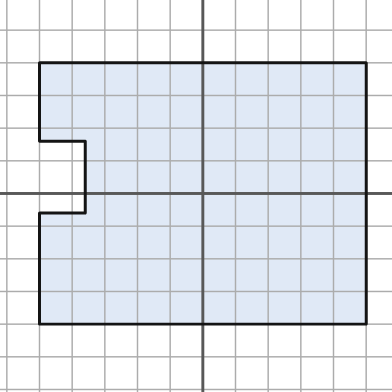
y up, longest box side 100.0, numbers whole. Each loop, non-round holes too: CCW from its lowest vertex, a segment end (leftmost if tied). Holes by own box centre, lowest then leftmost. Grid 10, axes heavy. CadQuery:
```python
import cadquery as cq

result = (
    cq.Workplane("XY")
    .moveTo(-50.0, -40.0)
    .lineTo(50.0, -40.0)
    .lineTo(50.0, 40.0)
    .lineTo(-50.0, 40.0)
    .lineTo(-50.0, 16.0)
    .lineTo(-36.0, 16.0)
    .lineTo(-36.0, -6.0)
    .lineTo(-50.0, -6.0)
    .close()
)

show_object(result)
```